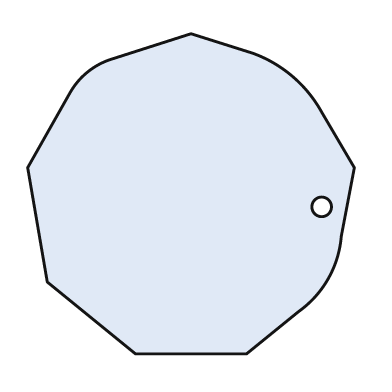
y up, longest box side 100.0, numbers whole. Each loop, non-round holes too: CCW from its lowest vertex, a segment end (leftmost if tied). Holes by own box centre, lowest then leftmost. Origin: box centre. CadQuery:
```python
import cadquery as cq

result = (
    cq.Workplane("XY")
    .moveTo(-17.0, -49.0)
    .lineTo(17.0, -49.0)
    .lineTo(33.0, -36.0)
    .threePointArc((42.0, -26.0), (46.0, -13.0))
    .lineTo(50.0, 8.0)
    .lineTo(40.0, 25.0)
    .threePointArc((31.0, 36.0), (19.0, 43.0))
    .lineTo(0.0, 49.0)
    .lineTo(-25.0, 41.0)
    .threePointArc((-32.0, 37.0), (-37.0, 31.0))
    .lineTo(-50.0, 8.0)
    .lineTo(-44.0, -27.0)
    .close()
    .moveTo(40.0, -4.0)
    .circle(3.0)
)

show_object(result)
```